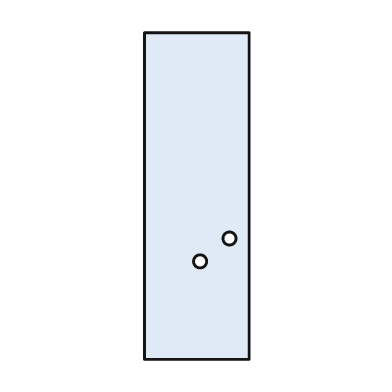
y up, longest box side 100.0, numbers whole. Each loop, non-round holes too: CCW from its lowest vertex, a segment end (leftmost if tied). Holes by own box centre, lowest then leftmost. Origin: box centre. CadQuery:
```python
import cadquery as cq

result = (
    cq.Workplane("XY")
    .moveTo(-16.0, -50.0)
    .lineTo(16.0, -50.0)
    .lineTo(16.0, 50.0)
    .lineTo(-16.0, 50.0)
    .close()
    .moveTo(1.0, -20.0)
    .circle(2.0)
    .moveTo(10.0, -13.0)
    .circle(2.0)
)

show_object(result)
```